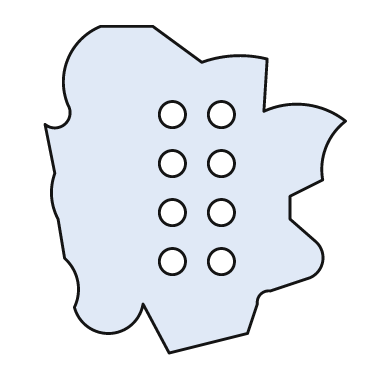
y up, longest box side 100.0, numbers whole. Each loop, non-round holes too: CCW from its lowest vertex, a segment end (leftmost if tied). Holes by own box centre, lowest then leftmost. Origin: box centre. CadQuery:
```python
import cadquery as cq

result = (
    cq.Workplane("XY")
    .moveTo(-8.0, -50.0)
    .lineTo(16.0, -44.0)
    .lineTo(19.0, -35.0)
    .threePointArc((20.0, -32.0), (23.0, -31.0))
    .lineTo(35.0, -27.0)
    .threePointArc((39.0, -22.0), (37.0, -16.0))
    .lineTo(29.0, -9.0)
    .lineTo(29.0, -2.0)
    .lineTo(39.0, 3.0)
    .threePointArc((40.0, 13.0), (46.0, 21.0))
    .threePointArc((34.0, 26.0), (21.0, 24.0))
    .lineTo(22.0, 40.0)
    .threePointArc((12.0, 41.0), (2.0, 39.0))
    .lineTo(-13.0, 50.0)
    .lineTo(-29.0, 50.0)
    .threePointArc((-39.0, 40.0), (-39.0, 26.0))
    .threePointArc((-40.0, 20.0), (-46.0, 20.0))
    .lineTo(-43.0, 5.0)
    .threePointArc((-44.0, -2.0), (-42.0, -9.0))
    .lineTo(-40.0, -21.0)
    .threePointArc((-36.0, -28.0), (-37.0, -36.0))
    .threePointArc((-26.0, -44.0), (-16.0, -35.0))
    .close()
    .moveTo(-7.0, -22.0)
    .circle(4.0)
    .moveTo(8.0, -22.0)
    .circle(4.0)
    .moveTo(-7.0, -7.0)
    .circle(4.0)
    .moveTo(8.0, -7.0)
    .circle(4.0)
    .moveTo(-7.0, 8.0)
    .circle(4.0)
    .moveTo(8.0, 8.0)
    .circle(4.0)
    .moveTo(-7.0, 23.0)
    .circle(4.0)
    .moveTo(8.0, 23.0)
    .circle(4.0)
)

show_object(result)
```